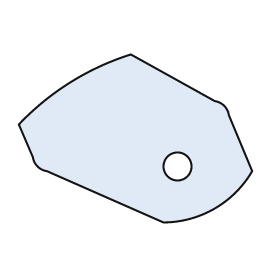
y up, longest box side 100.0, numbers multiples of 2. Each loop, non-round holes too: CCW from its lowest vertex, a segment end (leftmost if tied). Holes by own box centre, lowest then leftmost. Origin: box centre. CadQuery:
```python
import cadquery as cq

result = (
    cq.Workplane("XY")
    .moveTo(12.0, -36.0)
    .threePointArc((34.0, -30.0), (50.0, -14.0))
    .lineTo(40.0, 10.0)
    .threePointArc((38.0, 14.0), (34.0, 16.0))
    .lineTo(-2.0, 36.0)
    .threePointArc((-28.0, 24.0), (-50.0, 6.0))
    .lineTo(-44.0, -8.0)
    .threePointArc((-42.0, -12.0), (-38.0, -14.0))
    .close()
    .moveTo(18.0, -12.0)
    .circle(6.0)
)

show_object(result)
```